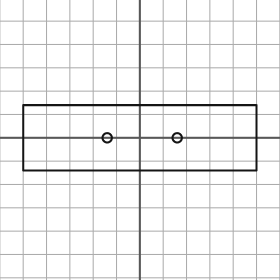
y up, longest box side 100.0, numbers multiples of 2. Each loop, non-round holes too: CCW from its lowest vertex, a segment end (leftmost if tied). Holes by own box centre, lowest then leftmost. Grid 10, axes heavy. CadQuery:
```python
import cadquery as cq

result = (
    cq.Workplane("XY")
    .moveTo(-50.0, -14.0)
    .lineTo(50.0, -14.0)
    .lineTo(50.0, 14.0)
    .lineTo(-50.0, 14.0)
    .close()
    .moveTo(-14.0, 0.0)
    .circle(2.0)
    .moveTo(16.0, 0.0)
    .circle(2.0)
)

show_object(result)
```